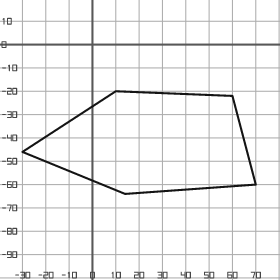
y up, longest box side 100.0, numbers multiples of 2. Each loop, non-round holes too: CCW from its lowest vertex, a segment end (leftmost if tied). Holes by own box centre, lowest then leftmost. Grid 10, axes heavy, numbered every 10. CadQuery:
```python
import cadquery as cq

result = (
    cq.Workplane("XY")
    .moveTo(14.0, -64.0)
    .lineTo(70.0, -60.0)
    .lineTo(60.0, -22.0)
    .lineTo(10.0, -20.0)
    .lineTo(-30.0, -46.0)
    .close()
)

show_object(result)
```